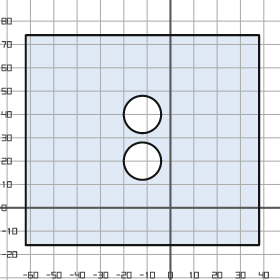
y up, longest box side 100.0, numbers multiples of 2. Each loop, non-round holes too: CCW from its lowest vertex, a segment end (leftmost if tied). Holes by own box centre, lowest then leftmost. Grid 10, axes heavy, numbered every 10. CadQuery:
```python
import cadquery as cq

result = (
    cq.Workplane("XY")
    .moveTo(-62.0, -16.0)
    .lineTo(38.0, -16.0)
    .lineTo(38.0, 74.0)
    .lineTo(-62.0, 74.0)
    .close()
    .moveTo(-12.0, 20.0)
    .circle(8.0)
    .moveTo(-12.0, 40.0)
    .circle(8.0)
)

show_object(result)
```